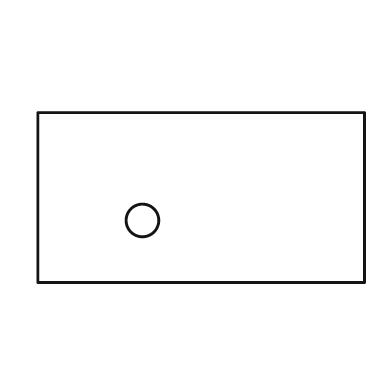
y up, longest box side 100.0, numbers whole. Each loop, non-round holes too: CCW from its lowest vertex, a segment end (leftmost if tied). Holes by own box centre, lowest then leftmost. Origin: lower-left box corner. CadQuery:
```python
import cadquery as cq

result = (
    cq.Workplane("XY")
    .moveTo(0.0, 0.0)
    .lineTo(100.0, 0.0)
    .lineTo(100.0, 52.0)
    .lineTo(0.0, 52.0)
    .close()
    .moveTo(32.0, 19.0)
    .circle(5.0)
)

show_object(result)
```